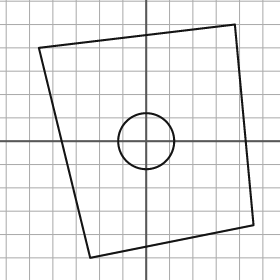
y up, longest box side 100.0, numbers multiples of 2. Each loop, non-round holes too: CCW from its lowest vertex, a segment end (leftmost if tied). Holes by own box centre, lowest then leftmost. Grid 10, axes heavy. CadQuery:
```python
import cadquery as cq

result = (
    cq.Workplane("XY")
    .moveTo(-24.0, -50.0)
    .lineTo(46.0, -36.0)
    .lineTo(38.0, 50.0)
    .lineTo(-46.0, 40.0)
    .close()
    .moveTo(0.0, 0.0)
    .circle(12.0)
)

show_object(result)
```